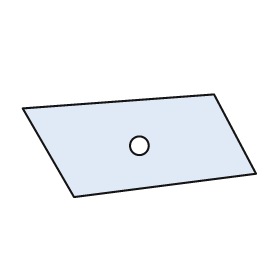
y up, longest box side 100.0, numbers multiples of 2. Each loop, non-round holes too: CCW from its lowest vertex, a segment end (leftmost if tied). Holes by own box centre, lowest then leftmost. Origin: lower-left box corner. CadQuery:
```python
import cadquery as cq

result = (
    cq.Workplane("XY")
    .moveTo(22.0, 0.0)
    .lineTo(100.0, 10.0)
    .lineTo(82.0, 44.0)
    .lineTo(0.0, 38.0)
    .close()
    .moveTo(50.0, 22.0)
    .circle(4.0)
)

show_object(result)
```